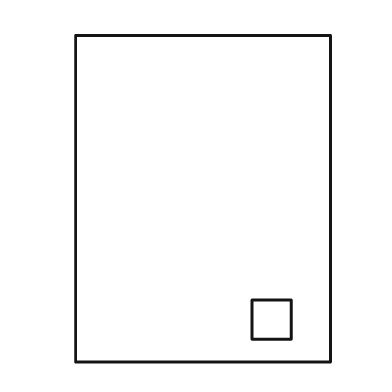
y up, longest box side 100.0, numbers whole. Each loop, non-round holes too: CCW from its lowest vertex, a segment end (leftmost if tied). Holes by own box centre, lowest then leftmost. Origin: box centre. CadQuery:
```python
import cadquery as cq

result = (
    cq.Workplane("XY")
    .moveTo(-39.0, -50.0)
    .lineTo(39.0, -50.0)
    .lineTo(39.0, 50.0)
    .lineTo(-39.0, 50.0)
    .close()
    .moveTo(15.0, -43.0)
    .lineTo(27.0, -43.0)
    .lineTo(27.0, -31.0)
    .lineTo(15.0, -31.0)
    .close()
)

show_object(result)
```